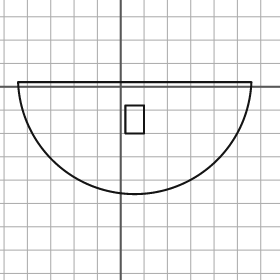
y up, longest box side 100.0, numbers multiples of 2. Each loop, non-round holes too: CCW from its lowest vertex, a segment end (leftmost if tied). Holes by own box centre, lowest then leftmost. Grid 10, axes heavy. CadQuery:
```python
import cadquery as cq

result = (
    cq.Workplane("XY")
    .moveTo(-44.0, 2.0)
    .threePointArc((6.0, -46.0), (56.0, 2.0))
    .close()
    .moveTo(2.0, -20.0)
    .lineTo(10.0, -20.0)
    .lineTo(10.0, -8.0)
    .lineTo(2.0, -8.0)
    .close()
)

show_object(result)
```